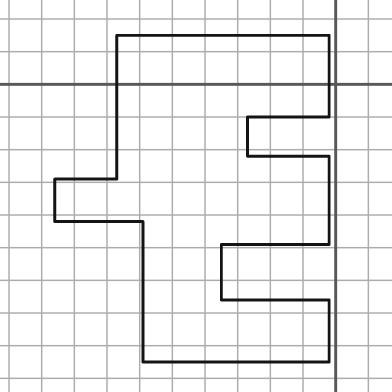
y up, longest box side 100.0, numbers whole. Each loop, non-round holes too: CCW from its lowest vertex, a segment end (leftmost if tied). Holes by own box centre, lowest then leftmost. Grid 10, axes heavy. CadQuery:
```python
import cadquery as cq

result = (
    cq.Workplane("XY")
    .moveTo(-59.0, -85.0)
    .lineTo(-2.0, -85.0)
    .lineTo(-2.0, -66.0)
    .lineTo(-35.0, -66.0)
    .lineTo(-35.0, -49.0)
    .lineTo(-2.0, -49.0)
    .lineTo(-2.0, -22.0)
    .lineTo(-27.0, -22.0)
    .lineTo(-27.0, -10.0)
    .lineTo(-2.0, -10.0)
    .lineTo(-2.0, 15.0)
    .lineTo(-67.0, 15.0)
    .lineTo(-67.0, -29.0)
    .lineTo(-86.0, -29.0)
    .lineTo(-86.0, -42.0)
    .lineTo(-59.0, -42.0)
    .close()
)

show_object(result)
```